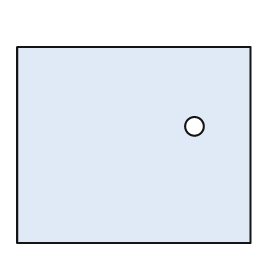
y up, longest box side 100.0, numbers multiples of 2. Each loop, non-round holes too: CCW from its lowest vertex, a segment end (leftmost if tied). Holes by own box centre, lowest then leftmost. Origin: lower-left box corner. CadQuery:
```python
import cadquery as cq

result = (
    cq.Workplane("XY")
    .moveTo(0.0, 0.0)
    .lineTo(100.0, 0.0)
    .lineTo(100.0, 84.0)
    .lineTo(0.0, 84.0)
    .close()
    .moveTo(76.0, 50.0)
    .circle(4.0)
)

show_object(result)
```